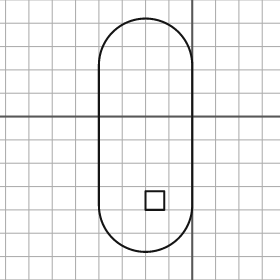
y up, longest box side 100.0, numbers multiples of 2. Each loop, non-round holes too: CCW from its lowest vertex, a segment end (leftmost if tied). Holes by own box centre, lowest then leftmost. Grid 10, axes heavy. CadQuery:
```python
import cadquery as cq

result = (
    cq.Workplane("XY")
    .moveTo(-40.0, -38.0)
    .threePointArc((-20.0, -58.0), (0.0, -38.0))
    .lineTo(0.0, 22.0)
    .threePointArc((-20.0, 42.0), (-40.0, 22.0))
    .close()
    .moveTo(-20.0, -40.0)
    .lineTo(-12.0, -40.0)
    .lineTo(-12.0, -32.0)
    .lineTo(-20.0, -32.0)
    .close()
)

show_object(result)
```